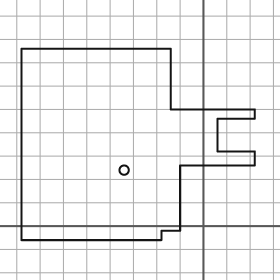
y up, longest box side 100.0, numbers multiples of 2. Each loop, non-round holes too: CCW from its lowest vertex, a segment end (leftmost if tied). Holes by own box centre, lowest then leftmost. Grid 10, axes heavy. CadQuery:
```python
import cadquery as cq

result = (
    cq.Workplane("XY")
    .moveTo(-78.0, -6.0)
    .lineTo(-18.0, -6.0)
    .lineTo(-18.0, -2.0)
    .lineTo(-10.0, -2.0)
    .lineTo(-10.0, 26.0)
    .lineTo(22.0, 26.0)
    .lineTo(22.0, 32.0)
    .lineTo(6.0, 32.0)
    .lineTo(6.0, 46.0)
    .lineTo(22.0, 46.0)
    .lineTo(22.0, 50.0)
    .lineTo(-14.0, 50.0)
    .lineTo(-14.0, 76.0)
    .lineTo(-78.0, 76.0)
    .close()
    .moveTo(-34.0, 24.0)
    .circle(2.0)
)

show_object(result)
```